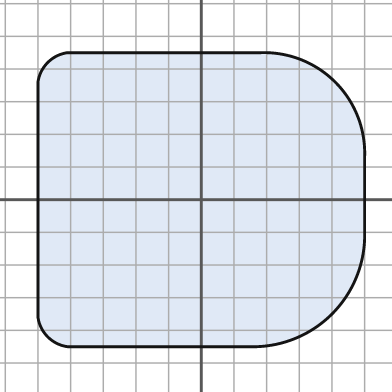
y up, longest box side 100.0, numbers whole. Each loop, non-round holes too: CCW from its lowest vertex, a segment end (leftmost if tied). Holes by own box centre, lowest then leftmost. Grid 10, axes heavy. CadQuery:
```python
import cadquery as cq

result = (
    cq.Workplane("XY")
    .moveTo(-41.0, -45.0)
    .lineTo(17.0, -45.0)
    .threePointArc((40.0, -35.0), (50.0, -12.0))
    .lineTo(50.0, 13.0)
    .threePointArc((41.0, 36.0), (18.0, 45.0))
    .lineTo(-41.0, 45.0)
    .threePointArc((-47.0, 42.0), (-50.0, 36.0))
    .lineTo(-50.0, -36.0)
    .threePointArc((-47.0, -42.0), (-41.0, -45.0))
    .close()
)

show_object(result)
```